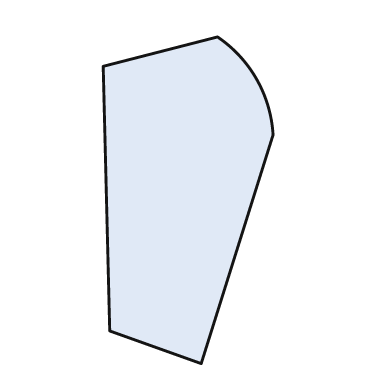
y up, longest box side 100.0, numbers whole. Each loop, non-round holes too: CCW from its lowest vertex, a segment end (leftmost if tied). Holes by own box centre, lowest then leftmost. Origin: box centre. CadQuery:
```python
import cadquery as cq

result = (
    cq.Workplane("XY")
    .moveTo(4.0, -50.0)
    .lineTo(26.0, 20.0)
    .threePointArc((21.0, 37.0), (9.0, 50.0))
    .lineTo(-26.0, 41.0)
    .lineTo(-24.0, -40.0)
    .close()
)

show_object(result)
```